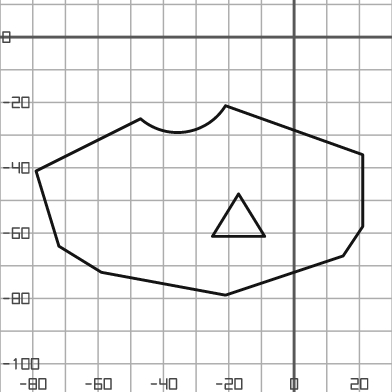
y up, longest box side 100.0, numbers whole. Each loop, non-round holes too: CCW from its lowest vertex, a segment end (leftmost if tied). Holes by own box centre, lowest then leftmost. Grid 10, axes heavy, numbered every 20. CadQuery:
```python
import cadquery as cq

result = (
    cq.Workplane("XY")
    .moveTo(-21.0, -79.0)
    .lineTo(15.0, -67.0)
    .lineTo(21.0, -58.0)
    .lineTo(21.0, -36.0)
    .lineTo(-21.0, -21.0)
    .threePointArc((-33.0, -29.0), (-47.0, -25.0))
    .lineTo(-79.0, -41.0)
    .lineTo(-72.0, -64.0)
    .lineTo(-59.0, -72.0)
    .close()
    .moveTo(-25.0, -61.0)
    .lineTo(-9.0, -61.0)
    .lineTo(-17.0, -48.0)
    .close()
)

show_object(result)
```